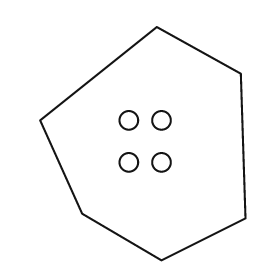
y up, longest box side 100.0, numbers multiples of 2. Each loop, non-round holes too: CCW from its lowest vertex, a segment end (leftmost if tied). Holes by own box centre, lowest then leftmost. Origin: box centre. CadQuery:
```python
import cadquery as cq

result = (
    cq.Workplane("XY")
    .moveTo(8.0, -50.0)
    .lineTo(44.0, -32.0)
    .lineTo(42.0, 30.0)
    .lineTo(6.0, 50.0)
    .lineTo(-44.0, 10.0)
    .lineTo(-26.0, -30.0)
    .close()
    .moveTo(-6.0, -8.0)
    .circle(4.0)
    .moveTo(8.0, -8.0)
    .circle(4.0)
    .moveTo(-6.0, 10.0)
    .circle(4.0)
    .moveTo(8.0, 10.0)
    .circle(4.0)
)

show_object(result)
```